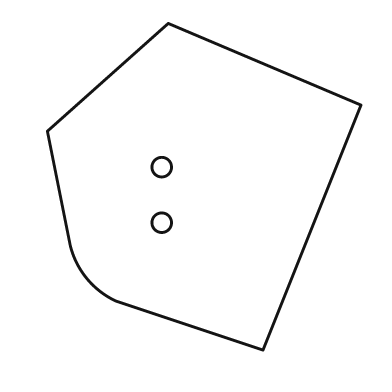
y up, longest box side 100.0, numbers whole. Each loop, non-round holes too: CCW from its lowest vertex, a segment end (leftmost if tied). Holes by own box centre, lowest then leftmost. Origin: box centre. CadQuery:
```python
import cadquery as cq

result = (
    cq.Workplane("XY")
    .moveTo(18.0, -50.0)
    .lineTo(48.0, 25.0)
    .lineTo(-11.0, 50.0)
    .lineTo(-48.0, 17.0)
    .lineTo(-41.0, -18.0)
    .threePointArc((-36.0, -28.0), (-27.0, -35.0))
    .close()
    .moveTo(-13.0, -11.0)
    .circle(3.0)
    .moveTo(-13.0, 6.0)
    .circle(3.0)
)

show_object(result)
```